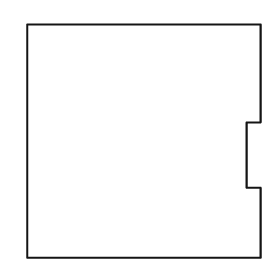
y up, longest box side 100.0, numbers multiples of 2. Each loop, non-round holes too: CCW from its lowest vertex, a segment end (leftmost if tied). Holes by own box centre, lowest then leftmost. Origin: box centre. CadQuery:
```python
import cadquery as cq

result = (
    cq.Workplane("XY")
    .moveTo(-50.0, -50.0)
    .lineTo(50.0, -50.0)
    .lineTo(50.0, -20.0)
    .lineTo(44.0, -20.0)
    .lineTo(44.0, 8.0)
    .lineTo(50.0, 8.0)
    .lineTo(50.0, 50.0)
    .lineTo(-50.0, 50.0)
    .close()
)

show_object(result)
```